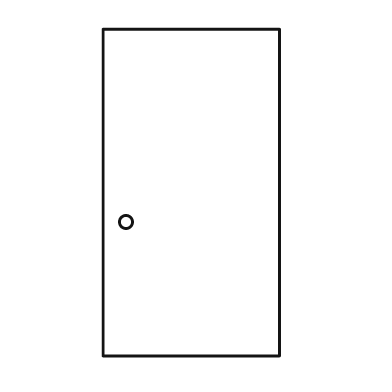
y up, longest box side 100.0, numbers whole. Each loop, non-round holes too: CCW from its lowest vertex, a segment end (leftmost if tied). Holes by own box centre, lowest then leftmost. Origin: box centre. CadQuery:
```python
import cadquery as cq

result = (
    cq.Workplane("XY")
    .moveTo(-27.0, -50.0)
    .lineTo(27.0, -50.0)
    .lineTo(27.0, 50.0)
    .lineTo(-27.0, 50.0)
    .close()
    .moveTo(-20.0, -9.0)
    .circle(2.0)
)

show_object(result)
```